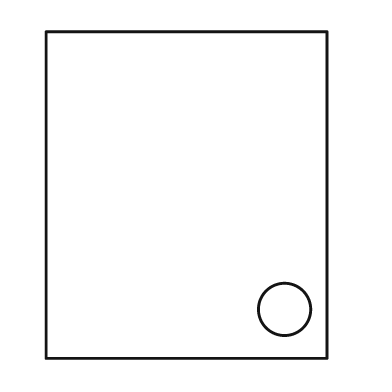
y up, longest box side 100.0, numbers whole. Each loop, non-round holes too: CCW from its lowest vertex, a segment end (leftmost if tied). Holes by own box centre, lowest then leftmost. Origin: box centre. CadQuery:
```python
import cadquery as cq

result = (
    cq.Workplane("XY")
    .moveTo(-43.0, -50.0)
    .lineTo(43.0, -50.0)
    .lineTo(43.0, 50.0)
    .lineTo(-43.0, 50.0)
    .close()
    .moveTo(30.0, -35.0)
    .circle(8.0)
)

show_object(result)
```